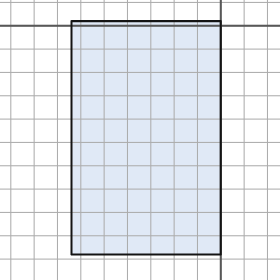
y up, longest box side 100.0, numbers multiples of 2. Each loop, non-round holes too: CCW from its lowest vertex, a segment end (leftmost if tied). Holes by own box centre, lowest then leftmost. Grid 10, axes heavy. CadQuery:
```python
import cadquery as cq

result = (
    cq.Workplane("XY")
    .moveTo(-64.0, -98.0)
    .lineTo(0.0, -98.0)
    .lineTo(0.0, 2.0)
    .lineTo(-64.0, 2.0)
    .close()
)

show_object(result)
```